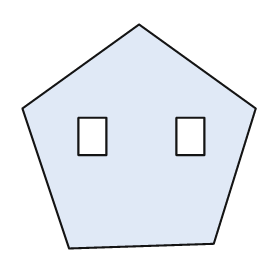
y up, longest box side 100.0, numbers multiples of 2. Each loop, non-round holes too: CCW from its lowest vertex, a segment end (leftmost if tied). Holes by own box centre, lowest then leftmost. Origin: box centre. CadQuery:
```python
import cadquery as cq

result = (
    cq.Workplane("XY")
    .moveTo(-30.0, -48.0)
    .lineTo(32.0, -46.0)
    .lineTo(50.0, 12.0)
    .lineTo(0.0, 48.0)
    .lineTo(-50.0, 12.0)
    .close()
    .moveTo(-26.0, -8.0)
    .lineTo(-14.0, -8.0)
    .lineTo(-14.0, 8.0)
    .lineTo(-26.0, 8.0)
    .close()
    .moveTo(16.0, -8.0)
    .lineTo(28.0, -8.0)
    .lineTo(28.0, 8.0)
    .lineTo(16.0, 8.0)
    .close()
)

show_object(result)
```